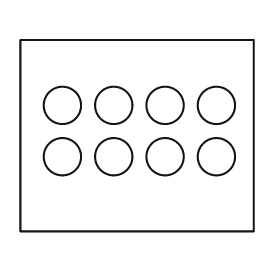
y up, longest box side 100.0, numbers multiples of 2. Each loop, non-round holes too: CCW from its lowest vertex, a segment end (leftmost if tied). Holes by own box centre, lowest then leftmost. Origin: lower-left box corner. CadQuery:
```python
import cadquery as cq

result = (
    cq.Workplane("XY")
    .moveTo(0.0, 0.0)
    .lineTo(100.0, 0.0)
    .lineTo(100.0, 82.0)
    .lineTo(0.0, 82.0)
    .close()
    .moveTo(18.0, 32.0)
    .circle(8.0)
    .moveTo(40.0, 32.0)
    .circle(8.0)
    .moveTo(62.0, 32.0)
    .circle(8.0)
    .moveTo(84.0, 32.0)
    .circle(8.0)
    .moveTo(18.0, 54.0)
    .circle(8.0)
    .moveTo(40.0, 54.0)
    .circle(8.0)
    .moveTo(62.0, 54.0)
    .circle(8.0)
    .moveTo(84.0, 54.0)
    .circle(8.0)
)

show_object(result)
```